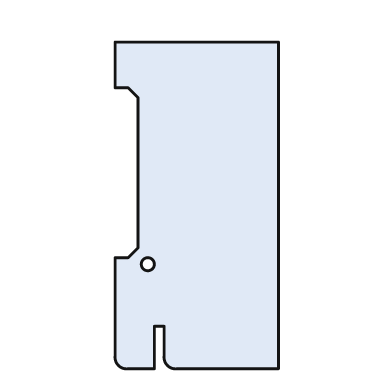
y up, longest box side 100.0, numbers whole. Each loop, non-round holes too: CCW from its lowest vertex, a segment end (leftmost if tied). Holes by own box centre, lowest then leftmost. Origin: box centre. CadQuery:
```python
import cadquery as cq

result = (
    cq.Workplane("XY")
    .moveTo(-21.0, -50.0)
    .lineTo(-13.0, -50.0)
    .lineTo(-13.0, -37.0)
    .lineTo(-10.0, -37.0)
    .lineTo(-10.0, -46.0)
    .threePointArc((-9.0, -49.0), (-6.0, -50.0))
    .lineTo(25.0, -50.0)
    .lineTo(25.0, 50.0)
    .lineTo(-25.0, 50.0)
    .lineTo(-25.0, 36.0)
    .lineTo(-21.0, 36.0)
    .lineTo(-18.0, 33.0)
    .lineTo(-18.0, -13.0)
    .lineTo(-21.0, -16.0)
    .lineTo(-25.0, -16.0)
    .lineTo(-25.0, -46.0)
    .threePointArc((-24.0, -49.0), (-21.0, -50.0))
    .close()
    .moveTo(-15.0, -18.0)
    .circle(2.0)
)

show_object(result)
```